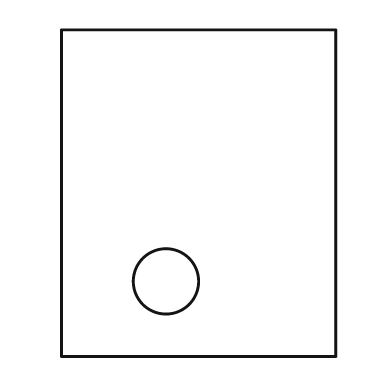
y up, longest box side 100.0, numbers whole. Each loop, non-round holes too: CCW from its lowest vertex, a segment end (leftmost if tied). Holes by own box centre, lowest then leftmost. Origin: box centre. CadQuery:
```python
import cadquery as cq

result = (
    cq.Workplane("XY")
    .moveTo(-42.0, -50.0)
    .lineTo(42.0, -50.0)
    .lineTo(42.0, 50.0)
    .lineTo(-42.0, 50.0)
    .close()
    .moveTo(-10.0, -27.0)
    .circle(10.0)
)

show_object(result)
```